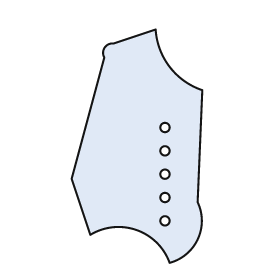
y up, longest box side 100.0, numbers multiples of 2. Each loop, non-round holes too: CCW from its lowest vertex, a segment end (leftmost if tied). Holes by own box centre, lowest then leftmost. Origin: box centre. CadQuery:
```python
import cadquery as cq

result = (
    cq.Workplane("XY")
    .moveTo(14.0, -50.0)
    .threePointArc((26.0, -40.0), (26.0, -24.0))
    .lineTo(28.0, 24.0)
    .threePointArc((14.0, 34.0), (8.0, 50.0))
    .lineTo(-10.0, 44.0)
    .threePointArc((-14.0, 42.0), (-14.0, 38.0))
    .lineTo(-28.0, -14.0)
    .lineTo(-20.0, -38.0)
    .threePointArc((0.0, -36.0), (14.0, -50.0))
    .close()
    .moveTo(12.0, -32.0)
    .circle(2.0)
    .moveTo(12.0, -22.0)
    .circle(2.0)
    .moveTo(12.0, -12.0)
    .circle(2.0)
    .moveTo(12.0, -2.0)
    .circle(2.0)
    .moveTo(12.0, 8.0)
    .circle(2.0)
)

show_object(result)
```